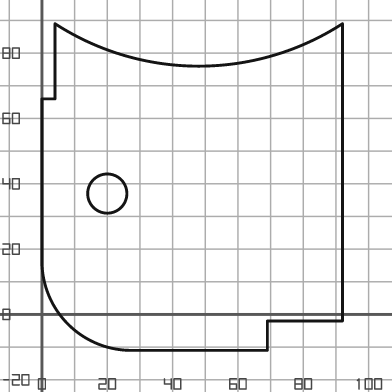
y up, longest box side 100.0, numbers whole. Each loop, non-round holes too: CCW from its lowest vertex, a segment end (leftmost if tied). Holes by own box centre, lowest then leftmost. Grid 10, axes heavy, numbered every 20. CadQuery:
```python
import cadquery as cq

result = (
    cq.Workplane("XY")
    .moveTo(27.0, -11.0)
    .lineTo(69.0, -11.0)
    .lineTo(69.0, -2.0)
    .lineTo(92.0, -2.0)
    .lineTo(92.0, 89.0)
    .threePointArc((48.0, 76.0), (4.0, 89.0))
    .lineTo(4.0, 66.0)
    .lineTo(0.0, 66.0)
    .lineTo(0.0, 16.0)
    .threePointArc((8.0, -3.0), (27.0, -11.0))
    .close()
    .moveTo(20.0, 37.0)
    .circle(6.0)
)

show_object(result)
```